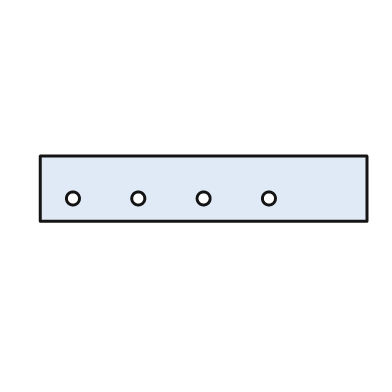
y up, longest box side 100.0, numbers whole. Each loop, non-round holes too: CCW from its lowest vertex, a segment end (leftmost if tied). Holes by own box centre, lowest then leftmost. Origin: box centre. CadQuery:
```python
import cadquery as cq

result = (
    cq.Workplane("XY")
    .moveTo(-50.0, -10.0)
    .lineTo(50.0, -10.0)
    .lineTo(50.0, 10.0)
    .lineTo(-50.0, 10.0)
    .close()
    .moveTo(-40.0, -3.0)
    .circle(2.0)
    .moveTo(-20.0, -3.0)
    .circle(2.0)
    .moveTo(0.0, -3.0)
    .circle(2.0)
    .moveTo(20.0, -3.0)
    .circle(2.0)
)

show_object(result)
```